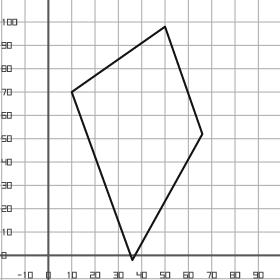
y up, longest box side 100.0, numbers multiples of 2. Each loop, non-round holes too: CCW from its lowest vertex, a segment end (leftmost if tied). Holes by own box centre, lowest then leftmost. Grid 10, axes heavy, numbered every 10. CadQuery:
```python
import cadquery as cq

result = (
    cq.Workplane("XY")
    .moveTo(36.0, -2.0)
    .lineTo(66.0, 52.0)
    .lineTo(50.0, 98.0)
    .lineTo(10.0, 70.0)
    .close()
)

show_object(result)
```